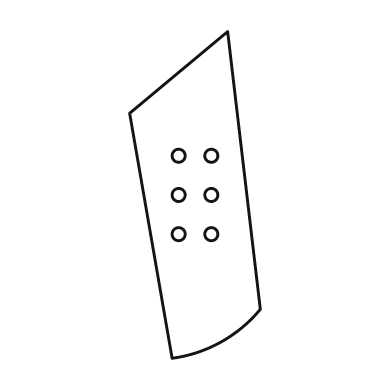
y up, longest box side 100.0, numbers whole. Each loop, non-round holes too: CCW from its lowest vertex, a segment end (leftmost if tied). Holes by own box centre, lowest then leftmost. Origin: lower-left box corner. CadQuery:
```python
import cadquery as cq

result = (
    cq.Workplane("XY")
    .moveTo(13.0, 0.0)
    .threePointArc((28.0, 5.0), (40.0, 15.0))
    .lineTo(30.0, 100.0)
    .lineTo(0.0, 75.0)
    .close()
    .moveTo(15.0, 38.0)
    .circle(2.0)
    .moveTo(25.0, 38.0)
    .circle(2.0)
    .moveTo(15.0, 50.0)
    .circle(2.0)
    .moveTo(25.0, 50.0)
    .circle(2.0)
    .moveTo(15.0, 62.0)
    .circle(2.0)
    .moveTo(25.0, 62.0)
    .circle(2.0)
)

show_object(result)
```